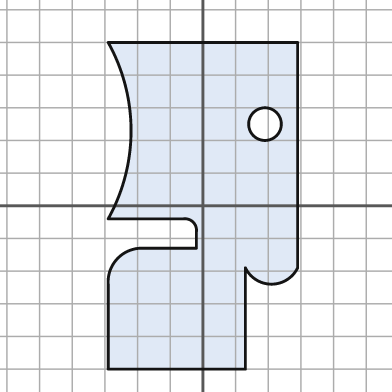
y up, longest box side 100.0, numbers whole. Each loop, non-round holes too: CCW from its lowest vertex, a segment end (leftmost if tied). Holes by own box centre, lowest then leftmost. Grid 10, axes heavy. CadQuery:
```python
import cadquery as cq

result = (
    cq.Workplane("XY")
    .moveTo(-29.0, -50.0)
    .lineTo(13.0, -50.0)
    .lineTo(13.0, -19.0)
    .threePointArc((21.0, -24.0), (29.0, -19.0))
    .lineTo(29.0, 50.0)
    .lineTo(-29.0, 50.0)
    .threePointArc((-22.0, 23.0), (-29.0, -4.0))
    .lineTo(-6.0, -4.0)
    .threePointArc((-3.0, -5.0), (-2.0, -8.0))
    .lineTo(-2.0, -13.0)
    .lineTo(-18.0, -13.0)
    .threePointArc((-26.0, -16.0), (-29.0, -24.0))
    .close()
    .moveTo(19.0, 25.0)
    .circle(5.0)
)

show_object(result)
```